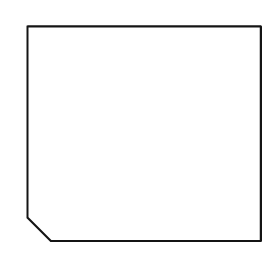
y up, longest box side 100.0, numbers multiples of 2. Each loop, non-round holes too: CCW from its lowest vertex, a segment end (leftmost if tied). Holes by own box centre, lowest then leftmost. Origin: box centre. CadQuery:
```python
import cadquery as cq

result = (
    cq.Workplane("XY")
    .moveTo(-40.0, -46.0)
    .lineTo(50.0, -46.0)
    .lineTo(50.0, 46.0)
    .lineTo(-50.0, 46.0)
    .lineTo(-50.0, -36.0)
    .close()
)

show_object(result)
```